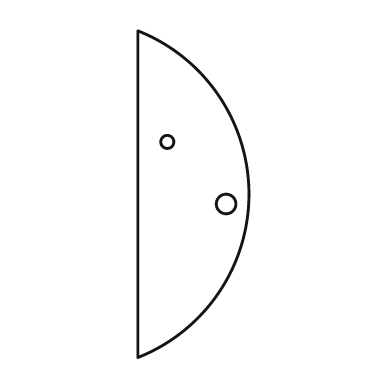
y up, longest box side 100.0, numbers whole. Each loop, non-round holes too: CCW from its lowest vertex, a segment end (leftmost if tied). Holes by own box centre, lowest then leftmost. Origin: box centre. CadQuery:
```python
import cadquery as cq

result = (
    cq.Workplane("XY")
    .moveTo(-17.0, -50.0)
    .threePointArc((17.0, 0.0), (-17.0, 50.0))
    .close()
    .moveTo(10.0, -3.0)
    .circle(3.0)
    .moveTo(-8.0, 16.0)
    .circle(2.0)
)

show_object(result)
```